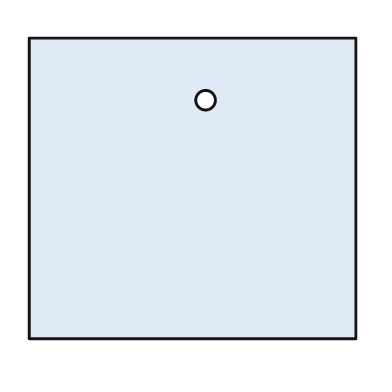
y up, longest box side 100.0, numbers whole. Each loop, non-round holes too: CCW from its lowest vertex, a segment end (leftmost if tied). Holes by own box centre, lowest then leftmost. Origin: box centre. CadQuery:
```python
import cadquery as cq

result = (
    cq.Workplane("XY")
    .moveTo(-50.0, -46.0)
    .lineTo(50.0, -46.0)
    .lineTo(50.0, 46.0)
    .lineTo(-50.0, 46.0)
    .close()
    .moveTo(4.0, 27.0)
    .circle(3.0)
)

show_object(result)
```